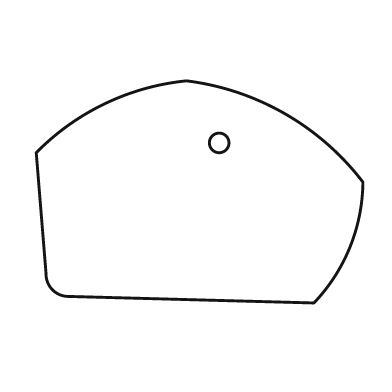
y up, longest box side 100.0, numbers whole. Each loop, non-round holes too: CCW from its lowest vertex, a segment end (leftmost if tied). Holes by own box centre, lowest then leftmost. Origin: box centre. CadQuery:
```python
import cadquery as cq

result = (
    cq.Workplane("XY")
    .moveTo(35.0, -34.0)
    .threePointArc((46.0, -17.0), (50.0, 3.0))
    .threePointArc((26.0, 24.0), (-4.0, 34.0))
    .threePointArc((-29.0, 27.0), (-50.0, 12.0))
    .lineTo(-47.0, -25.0)
    .threePointArc((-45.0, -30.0), (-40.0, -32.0))
    .close()
    .moveTo(6.0, 15.0)
    .circle(3.0)
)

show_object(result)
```